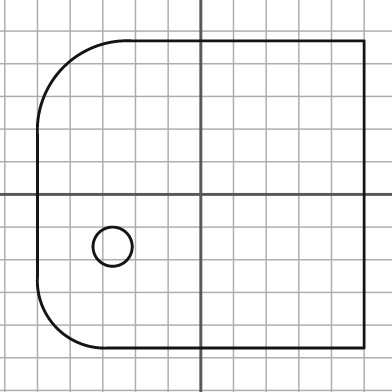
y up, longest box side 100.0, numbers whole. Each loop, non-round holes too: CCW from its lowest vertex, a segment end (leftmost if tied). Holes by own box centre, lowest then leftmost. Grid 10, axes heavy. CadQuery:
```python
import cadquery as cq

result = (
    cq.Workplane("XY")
    .moveTo(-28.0, -47.0)
    .lineTo(50.0, -47.0)
    .lineTo(50.0, 47.0)
    .lineTo(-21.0, 47.0)
    .threePointArc((-42.0, 39.0), (-50.0, 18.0))
    .lineTo(-50.0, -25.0)
    .threePointArc((-44.0, -41.0), (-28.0, -47.0))
    .close()
    .moveTo(-27.0, -16.0)
    .circle(6.0)
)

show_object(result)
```